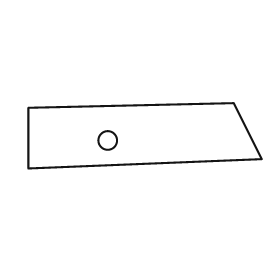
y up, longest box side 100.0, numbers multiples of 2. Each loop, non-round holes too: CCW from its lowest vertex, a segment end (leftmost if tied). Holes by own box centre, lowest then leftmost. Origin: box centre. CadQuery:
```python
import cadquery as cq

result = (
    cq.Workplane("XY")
    .moveTo(-50.0, -14.0)
    .lineTo(50.0, -10.0)
    .lineTo(38.0, 14.0)
    .lineTo(-50.0, 12.0)
    .close()
    .moveTo(-16.0, -2.0)
    .circle(4.0)
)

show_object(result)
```